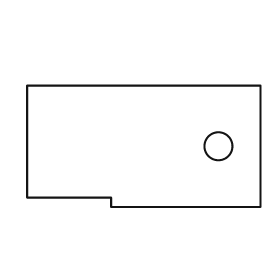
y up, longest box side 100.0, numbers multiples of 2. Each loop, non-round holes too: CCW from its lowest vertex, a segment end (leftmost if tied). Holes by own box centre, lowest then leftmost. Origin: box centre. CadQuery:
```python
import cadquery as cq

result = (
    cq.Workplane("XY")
    .moveTo(-14.0, -26.0)
    .lineTo(50.0, -26.0)
    .lineTo(50.0, 26.0)
    .lineTo(-50.0, 26.0)
    .lineTo(-50.0, -22.0)
    .lineTo(-14.0, -22.0)
    .close()
    .moveTo(32.0, 0.0)
    .circle(6.0)
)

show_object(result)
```